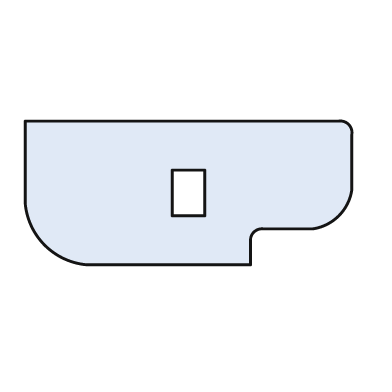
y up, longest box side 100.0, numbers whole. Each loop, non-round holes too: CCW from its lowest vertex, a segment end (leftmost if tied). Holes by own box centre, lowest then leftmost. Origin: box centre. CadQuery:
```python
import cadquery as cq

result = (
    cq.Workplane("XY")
    .moveTo(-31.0, -22.0)
    .lineTo(19.0, -22.0)
    .lineTo(19.0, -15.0)
    .threePointArc((20.0, -12.0), (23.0, -11.0))
    .lineTo(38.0, -11.0)
    .threePointArc((46.0, -7.0), (50.0, 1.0))
    .lineTo(50.0, 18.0)
    .threePointArc((49.0, 21.0), (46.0, 22.0))
    .lineTo(-50.0, 22.0)
    .lineTo(-50.0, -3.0)
    .threePointArc((-44.0, -16.0), (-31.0, -22.0))
    .close()
    .moveTo(-5.0, -7.0)
    .lineTo(5.0, -7.0)
    .lineTo(5.0, 7.0)
    .lineTo(-5.0, 7.0)
    .close()
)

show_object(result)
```